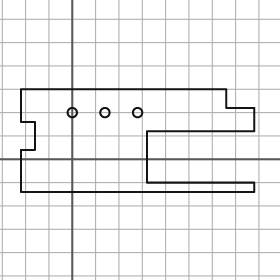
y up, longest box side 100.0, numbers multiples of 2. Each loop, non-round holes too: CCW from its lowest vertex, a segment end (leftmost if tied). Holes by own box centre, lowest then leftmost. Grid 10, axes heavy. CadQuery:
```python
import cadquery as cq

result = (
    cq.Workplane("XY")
    .moveTo(-22.0, -14.0)
    .lineTo(78.0, -14.0)
    .lineTo(78.0, -10.0)
    .lineTo(32.0, -10.0)
    .lineTo(32.0, 12.0)
    .lineTo(78.0, 12.0)
    .lineTo(78.0, 22.0)
    .lineTo(66.0, 22.0)
    .lineTo(66.0, 30.0)
    .lineTo(-22.0, 30.0)
    .lineTo(-22.0, 16.0)
    .lineTo(-16.0, 16.0)
    .lineTo(-16.0, 4.0)
    .lineTo(-22.0, 4.0)
    .close()
    .moveTo(0.0, 20.0)
    .circle(2.0)
    .moveTo(14.0, 20.0)
    .circle(2.0)
    .moveTo(28.0, 20.0)
    .circle(2.0)
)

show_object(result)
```